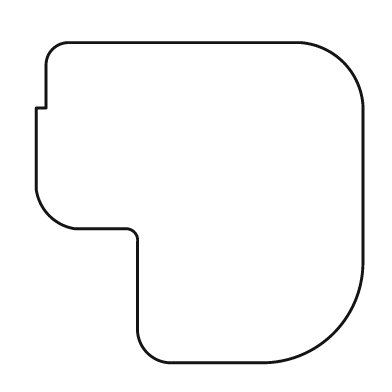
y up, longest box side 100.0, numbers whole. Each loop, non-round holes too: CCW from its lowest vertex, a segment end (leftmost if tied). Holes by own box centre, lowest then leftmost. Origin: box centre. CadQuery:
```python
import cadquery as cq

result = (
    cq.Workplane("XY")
    .moveTo(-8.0, -49.0)
    .lineTo(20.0, -49.0)
    .threePointArc((41.0, -40.0), (50.0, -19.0))
    .lineTo(50.0, 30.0)
    .threePointArc((44.0, 43.0), (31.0, 49.0))
    .lineTo(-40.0, 49.0)
    .threePointArc((-45.0, 47.0), (-47.0, 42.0))
    .lineTo(-47.0, 29.0)
    .lineTo(-50.0, 29.0)
    .lineTo(-50.0, 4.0)
    .threePointArc((-46.0, -4.0), (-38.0, -8.0))
    .lineTo(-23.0, -8.0)
    .threePointArc((-20.0, -9.0), (-19.0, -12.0))
    .lineTo(-19.0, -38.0)
    .threePointArc((-16.0, -46.0), (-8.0, -49.0))
    .close()
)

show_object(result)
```